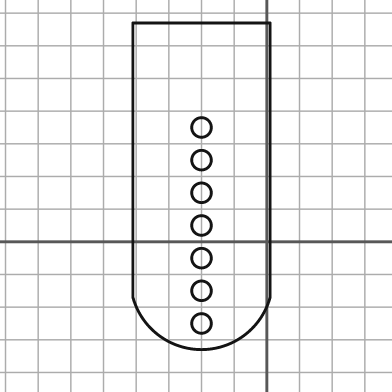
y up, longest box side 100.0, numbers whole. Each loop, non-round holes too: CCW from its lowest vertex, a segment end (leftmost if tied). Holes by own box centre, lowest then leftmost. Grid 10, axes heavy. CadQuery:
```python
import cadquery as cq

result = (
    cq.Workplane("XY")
    .moveTo(-41.0, -17.0)
    .threePointArc((-20.0, -33.0), (1.0, -17.0))
    .lineTo(1.0, 67.0)
    .lineTo(-41.0, 67.0)
    .close()
    .moveTo(-20.0, -25.0)
    .circle(3.0)
    .moveTo(-20.0, -15.0)
    .circle(3.0)
    .moveTo(-20.0, -5.0)
    .circle(3.0)
    .moveTo(-20.0, 5.0)
    .circle(3.0)
    .moveTo(-20.0, 15.0)
    .circle(3.0)
    .moveTo(-20.0, 25.0)
    .circle(3.0)
    .moveTo(-20.0, 35.0)
    .circle(3.0)
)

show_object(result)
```